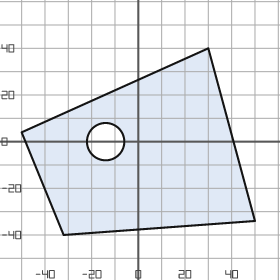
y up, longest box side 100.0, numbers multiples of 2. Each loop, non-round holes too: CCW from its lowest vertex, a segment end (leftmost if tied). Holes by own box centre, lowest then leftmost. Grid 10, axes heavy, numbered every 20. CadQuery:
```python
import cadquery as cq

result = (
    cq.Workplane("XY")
    .moveTo(-32.0, -40.0)
    .lineTo(50.0, -34.0)
    .lineTo(30.0, 40.0)
    .lineTo(-50.0, 4.0)
    .close()
    .moveTo(-14.0, 0.0)
    .circle(8.0)
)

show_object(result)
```